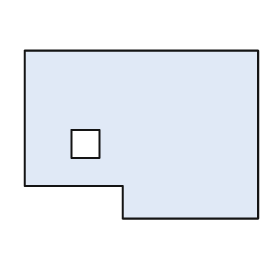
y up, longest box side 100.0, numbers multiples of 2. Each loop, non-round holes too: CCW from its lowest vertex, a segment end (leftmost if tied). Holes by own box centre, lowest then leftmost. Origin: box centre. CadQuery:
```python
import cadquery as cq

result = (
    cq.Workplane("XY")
    .moveTo(-8.0, -36.0)
    .lineTo(50.0, -36.0)
    .lineTo(50.0, 36.0)
    .lineTo(-50.0, 36.0)
    .lineTo(-50.0, -22.0)
    .lineTo(-8.0, -22.0)
    .close()
    .moveTo(-30.0, -10.0)
    .lineTo(-18.0, -10.0)
    .lineTo(-18.0, 2.0)
    .lineTo(-30.0, 2.0)
    .close()
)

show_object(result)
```